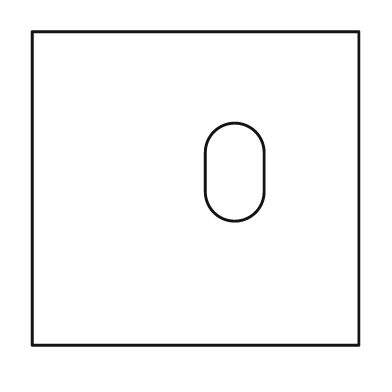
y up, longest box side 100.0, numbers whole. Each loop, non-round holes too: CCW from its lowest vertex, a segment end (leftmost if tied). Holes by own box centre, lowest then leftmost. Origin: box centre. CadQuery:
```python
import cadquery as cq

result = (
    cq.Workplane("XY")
    .moveTo(-50.0, -48.0)
    .lineTo(50.0, -48.0)
    .lineTo(50.0, 48.0)
    .lineTo(-50.0, 48.0)
    .close()
    .moveTo(3.0, -1.0)
    .threePointArc((12.0, -10.0), (21.0, -1.0))
    .lineTo(21.0, 11.0)
    .threePointArc((12.0, 20.0), (3.0, 11.0))
    .close()
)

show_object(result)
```